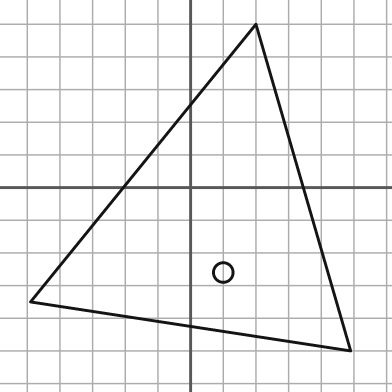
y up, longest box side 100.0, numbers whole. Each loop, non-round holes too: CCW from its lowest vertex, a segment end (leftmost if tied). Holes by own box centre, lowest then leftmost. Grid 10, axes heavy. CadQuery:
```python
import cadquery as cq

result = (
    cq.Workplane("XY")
    .moveTo(49.0, -50.0)
    .lineTo(20.0, 50.0)
    .lineTo(-49.0, -35.0)
    .close()
    .moveTo(10.0, -26.0)
    .circle(3.0)
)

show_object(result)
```